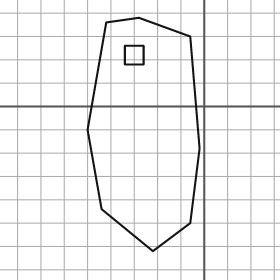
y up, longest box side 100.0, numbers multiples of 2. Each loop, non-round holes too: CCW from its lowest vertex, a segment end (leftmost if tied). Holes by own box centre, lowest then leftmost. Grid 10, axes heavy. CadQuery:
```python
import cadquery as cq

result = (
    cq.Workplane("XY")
    .moveTo(-22.0, -62.0)
    .lineTo(-6.0, -50.0)
    .lineTo(-2.0, -18.0)
    .lineTo(-6.0, 30.0)
    .lineTo(-28.0, 38.0)
    .lineTo(-42.0, 36.0)
    .lineTo(-50.0, -10.0)
    .lineTo(-44.0, -44.0)
    .close()
    .moveTo(-34.0, 18.0)
    .lineTo(-26.0, 18.0)
    .lineTo(-26.0, 26.0)
    .lineTo(-34.0, 26.0)
    .close()
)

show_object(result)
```